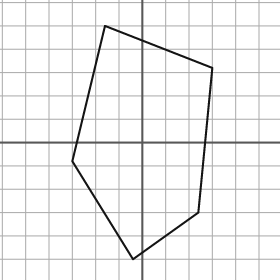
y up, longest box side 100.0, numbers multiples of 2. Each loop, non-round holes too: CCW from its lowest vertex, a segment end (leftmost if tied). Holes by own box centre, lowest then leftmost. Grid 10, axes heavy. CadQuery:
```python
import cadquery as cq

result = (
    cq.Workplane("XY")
    .moveTo(-4.0, -50.0)
    .lineTo(24.0, -30.0)
    .lineTo(30.0, 32.0)
    .lineTo(-16.0, 50.0)
    .lineTo(-30.0, -8.0)
    .close()
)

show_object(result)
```